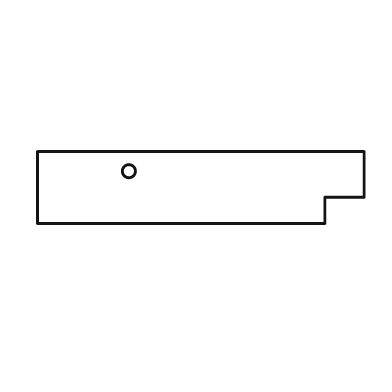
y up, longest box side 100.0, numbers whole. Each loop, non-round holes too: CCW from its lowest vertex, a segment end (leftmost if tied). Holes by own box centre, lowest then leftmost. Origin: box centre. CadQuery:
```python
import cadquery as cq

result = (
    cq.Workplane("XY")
    .moveTo(-50.0, -11.0)
    .lineTo(38.0, -11.0)
    .lineTo(38.0, -3.0)
    .lineTo(50.0, -3.0)
    .lineTo(50.0, 11.0)
    .lineTo(-50.0, 11.0)
    .close()
    .moveTo(-22.0, 5.0)
    .circle(2.0)
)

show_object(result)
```